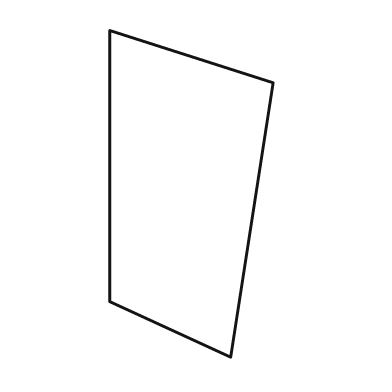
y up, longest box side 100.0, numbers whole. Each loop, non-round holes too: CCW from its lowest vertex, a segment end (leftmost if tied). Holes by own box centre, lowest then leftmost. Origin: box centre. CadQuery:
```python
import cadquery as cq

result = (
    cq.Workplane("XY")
    .moveTo(12.0, -50.0)
    .lineTo(25.0, 34.0)
    .lineTo(-25.0, 50.0)
    .lineTo(-25.0, -33.0)
    .close()
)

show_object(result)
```